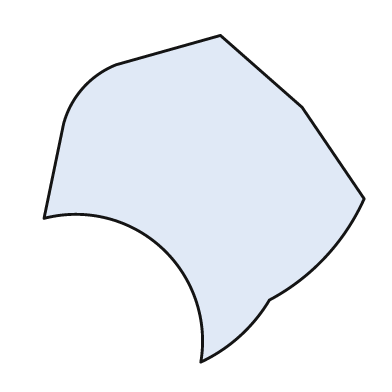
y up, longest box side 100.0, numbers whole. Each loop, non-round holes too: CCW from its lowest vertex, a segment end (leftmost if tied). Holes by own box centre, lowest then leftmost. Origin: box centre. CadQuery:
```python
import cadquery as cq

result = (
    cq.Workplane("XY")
    .moveTo(-1.0, -50.0)
    .threePointArc((11.0, -42.0), (20.0, -31.0))
    .threePointArc((37.0, -18.0), (49.0, 0.0))
    .lineTo(30.0, 28.0)
    .lineTo(5.0, 50.0)
    .lineTo(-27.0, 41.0)
    .threePointArc((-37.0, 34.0), (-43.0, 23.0))
    .lineTo(-49.0, -6.0)
    .threePointArc((-13.0, -15.0), (-1.0, -50.0))
    .close()
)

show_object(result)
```